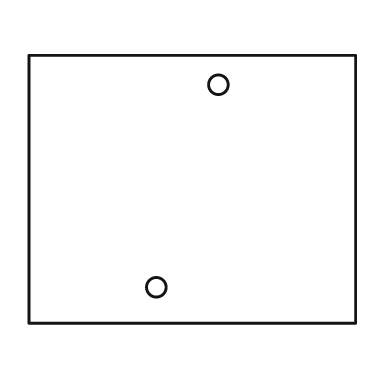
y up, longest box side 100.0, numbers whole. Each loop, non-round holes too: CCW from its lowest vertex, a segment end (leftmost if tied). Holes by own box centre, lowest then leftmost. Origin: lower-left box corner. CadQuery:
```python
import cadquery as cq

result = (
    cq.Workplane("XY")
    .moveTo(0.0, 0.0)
    .lineTo(100.0, 0.0)
    .lineTo(100.0, 82.0)
    .lineTo(0.0, 82.0)
    .close()
    .moveTo(39.0, 11.0)
    .circle(3.0)
    .moveTo(58.0, 73.0)
    .circle(3.0)
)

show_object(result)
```